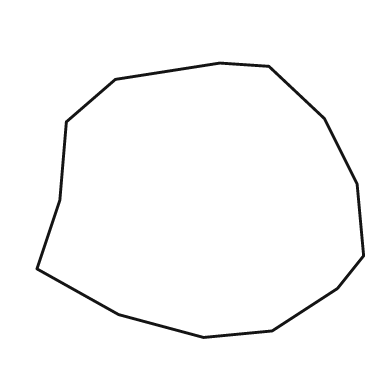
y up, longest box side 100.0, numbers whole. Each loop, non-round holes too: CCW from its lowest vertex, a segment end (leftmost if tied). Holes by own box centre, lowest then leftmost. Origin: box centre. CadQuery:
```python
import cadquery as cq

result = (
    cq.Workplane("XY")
    .moveTo(1.0, -42.0)
    .lineTo(22.0, -40.0)
    .lineTo(42.0, -27.0)
    .lineTo(50.0, -17.0)
    .lineTo(48.0, 5.0)
    .lineTo(38.0, 25.0)
    .lineTo(21.0, 41.0)
    .lineTo(6.0, 42.0)
    .lineTo(-26.0, 37.0)
    .lineTo(-41.0, 24.0)
    .lineTo(-43.0, 0.0)
    .lineTo(-50.0, -21.0)
    .lineTo(-25.0, -35.0)
    .close()
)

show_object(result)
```